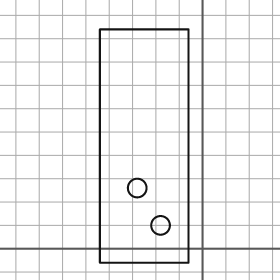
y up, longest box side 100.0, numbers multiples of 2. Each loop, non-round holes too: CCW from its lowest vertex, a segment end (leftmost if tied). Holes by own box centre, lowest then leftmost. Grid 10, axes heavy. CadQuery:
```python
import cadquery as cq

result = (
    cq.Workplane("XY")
    .moveTo(-44.0, -6.0)
    .lineTo(-6.0, -6.0)
    .lineTo(-6.0, 94.0)
    .lineTo(-44.0, 94.0)
    .close()
    .moveTo(-18.0, 10.0)
    .circle(4.0)
    .moveTo(-28.0, 26.0)
    .circle(4.0)
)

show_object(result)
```